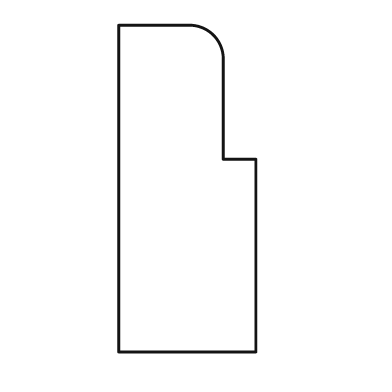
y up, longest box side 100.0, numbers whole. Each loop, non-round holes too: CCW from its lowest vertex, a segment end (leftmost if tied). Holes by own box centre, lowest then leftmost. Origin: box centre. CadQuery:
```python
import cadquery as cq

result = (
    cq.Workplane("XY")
    .moveTo(-21.0, -50.0)
    .lineTo(21.0, -50.0)
    .lineTo(21.0, 9.0)
    .lineTo(11.0, 9.0)
    .lineTo(11.0, 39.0)
    .threePointArc((8.0, 47.0), (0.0, 50.0))
    .lineTo(-21.0, 50.0)
    .close()
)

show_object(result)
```